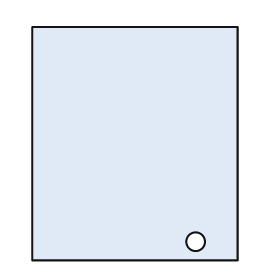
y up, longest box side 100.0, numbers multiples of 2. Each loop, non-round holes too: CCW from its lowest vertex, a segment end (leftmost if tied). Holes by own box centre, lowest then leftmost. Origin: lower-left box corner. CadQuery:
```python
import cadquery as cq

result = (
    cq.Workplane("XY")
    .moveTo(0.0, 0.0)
    .lineTo(88.0, 0.0)
    .lineTo(88.0, 100.0)
    .lineTo(0.0, 100.0)
    .close()
    .moveTo(70.0, 8.0)
    .circle(4.0)
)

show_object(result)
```